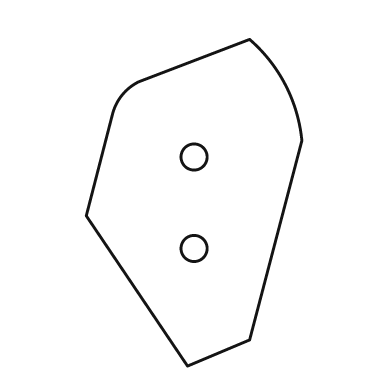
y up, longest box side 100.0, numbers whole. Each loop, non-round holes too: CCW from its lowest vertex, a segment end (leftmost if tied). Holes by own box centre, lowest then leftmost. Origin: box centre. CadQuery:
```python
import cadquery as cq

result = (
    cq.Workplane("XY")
    .moveTo(-2.0, -50.0)
    .lineTo(17.0, -42.0)
    .lineTo(33.0, 19.0)
    .threePointArc((28.0, 36.0), (17.0, 50.0))
    .lineTo(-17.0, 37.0)
    .threePointArc((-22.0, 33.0), (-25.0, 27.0))
    .lineTo(-33.0, -4.0)
    .close()
    .moveTo(0.0, -14.0)
    .circle(4.0)
    .moveTo(0.0, 14.0)
    .circle(4.0)
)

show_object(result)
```